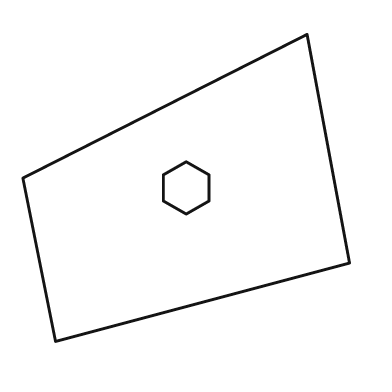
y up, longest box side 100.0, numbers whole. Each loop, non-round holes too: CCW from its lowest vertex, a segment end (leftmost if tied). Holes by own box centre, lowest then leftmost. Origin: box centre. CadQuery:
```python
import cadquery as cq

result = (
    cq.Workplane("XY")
    .moveTo(-40.0, -47.0)
    .lineTo(50.0, -23.0)
    .lineTo(37.0, 47.0)
    .lineTo(-50.0, 3.0)
    .close()
    .moveTo(0.0, -8.0)
    .lineTo(7.0, -4.0)
    .lineTo(7.0, 4.0)
    .lineTo(0.0, 8.0)
    .lineTo(-7.0, 4.0)
    .lineTo(-7.0, -4.0)
    .close()
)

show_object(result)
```